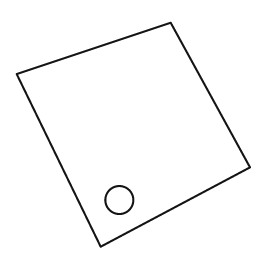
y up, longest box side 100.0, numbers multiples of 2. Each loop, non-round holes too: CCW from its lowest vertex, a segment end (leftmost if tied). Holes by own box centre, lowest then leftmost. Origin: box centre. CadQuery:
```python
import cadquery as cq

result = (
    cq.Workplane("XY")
    .moveTo(-14.0, -48.0)
    .lineTo(50.0, -14.0)
    .lineTo(16.0, 48.0)
    .lineTo(-50.0, 26.0)
    .close()
    .moveTo(-6.0, -28.0)
    .circle(6.0)
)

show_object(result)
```